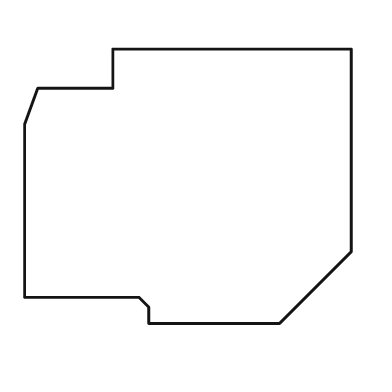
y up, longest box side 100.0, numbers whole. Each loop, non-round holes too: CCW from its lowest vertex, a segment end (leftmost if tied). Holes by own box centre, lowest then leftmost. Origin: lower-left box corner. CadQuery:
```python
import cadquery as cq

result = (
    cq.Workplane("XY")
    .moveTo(38.0, 0.0)
    .lineTo(78.0, 0.0)
    .lineTo(100.0, 22.0)
    .lineTo(100.0, 84.0)
    .lineTo(27.0, 84.0)
    .lineTo(27.0, 72.0)
    .lineTo(4.0, 72.0)
    .lineTo(0.0, 61.0)
    .lineTo(0.0, 8.0)
    .lineTo(35.0, 8.0)
    .lineTo(38.0, 5.0)
    .close()
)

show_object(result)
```